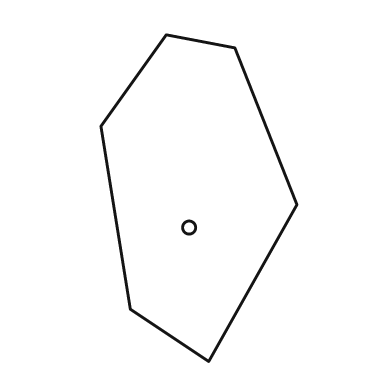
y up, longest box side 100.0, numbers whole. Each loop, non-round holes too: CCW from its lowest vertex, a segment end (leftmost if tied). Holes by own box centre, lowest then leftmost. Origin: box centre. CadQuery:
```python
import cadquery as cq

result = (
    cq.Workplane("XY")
    .moveTo(3.0, -50.0)
    .lineTo(30.0, -2.0)
    .lineTo(11.0, 46.0)
    .lineTo(-10.0, 50.0)
    .lineTo(-30.0, 22.0)
    .lineTo(-21.0, -34.0)
    .close()
    .moveTo(-3.0, -9.0)
    .circle(2.0)
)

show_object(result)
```